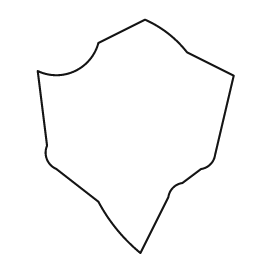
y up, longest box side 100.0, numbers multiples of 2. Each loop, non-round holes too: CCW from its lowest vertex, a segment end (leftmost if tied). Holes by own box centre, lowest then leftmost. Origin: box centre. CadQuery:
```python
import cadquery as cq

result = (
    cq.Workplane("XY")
    .moveTo(2.0, -50.0)
    .lineTo(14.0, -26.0)
    .threePointArc((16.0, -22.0), (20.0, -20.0))
    .lineTo(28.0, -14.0)
    .threePointArc((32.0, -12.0), (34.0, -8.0))
    .lineTo(42.0, 26.0)
    .lineTo(22.0, 36.0)
    .threePointArc((14.0, 44.0), (4.0, 50.0))
    .lineTo(-16.0, 40.0)
    .threePointArc((-26.0, 28.0), (-42.0, 28.0))
    .lineTo(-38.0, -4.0)
    .threePointArc((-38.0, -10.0), (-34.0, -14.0))
    .lineTo(-16.0, -28.0)
    .threePointArc((-8.0, -40.0), (2.0, -50.0))
    .close()
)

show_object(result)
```